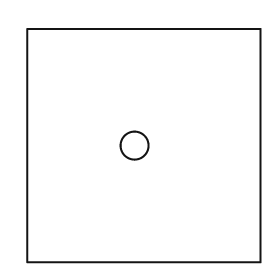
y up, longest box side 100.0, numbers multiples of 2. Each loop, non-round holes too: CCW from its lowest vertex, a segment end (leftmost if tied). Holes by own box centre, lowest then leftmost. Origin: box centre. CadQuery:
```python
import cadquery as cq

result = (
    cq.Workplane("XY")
    .moveTo(-50.0, -50.0)
    .lineTo(50.0, -50.0)
    .lineTo(50.0, 50.0)
    .lineTo(-50.0, 50.0)
    .close()
    .moveTo(-4.0, 0.0)
    .circle(6.0)
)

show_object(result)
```